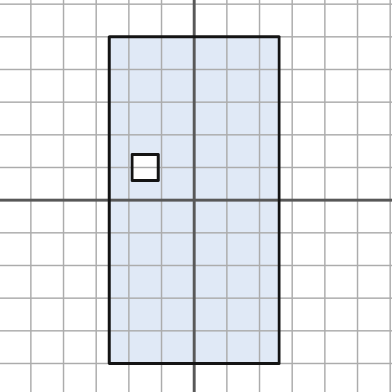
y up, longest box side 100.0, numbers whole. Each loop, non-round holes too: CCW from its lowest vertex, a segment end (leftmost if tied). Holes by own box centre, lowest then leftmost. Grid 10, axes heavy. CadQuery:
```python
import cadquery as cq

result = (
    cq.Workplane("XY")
    .moveTo(-26.0, -50.0)
    .lineTo(26.0, -50.0)
    .lineTo(26.0, 50.0)
    .lineTo(-26.0, 50.0)
    .close()
    .moveTo(-19.0, 6.0)
    .lineTo(-11.0, 6.0)
    .lineTo(-11.0, 14.0)
    .lineTo(-19.0, 14.0)
    .close()
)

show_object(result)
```